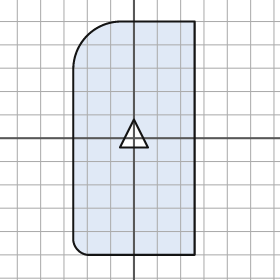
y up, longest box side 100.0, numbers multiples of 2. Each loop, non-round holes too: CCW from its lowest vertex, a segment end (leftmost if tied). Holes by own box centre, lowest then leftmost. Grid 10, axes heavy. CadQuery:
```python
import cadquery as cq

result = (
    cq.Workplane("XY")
    .moveTo(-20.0, -50.0)
    .lineTo(26.0, -50.0)
    .lineTo(26.0, 50.0)
    .lineTo(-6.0, 50.0)
    .threePointArc((-20.0, 44.0), (-26.0, 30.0))
    .lineTo(-26.0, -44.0)
    .threePointArc((-24.0, -48.0), (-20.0, -50.0))
    .close()
    .moveTo(-6.0, -4.0)
    .lineTo(6.0, -4.0)
    .lineTo(0.0, 8.0)
    .close()
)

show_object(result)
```